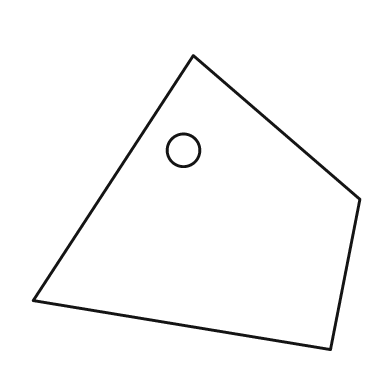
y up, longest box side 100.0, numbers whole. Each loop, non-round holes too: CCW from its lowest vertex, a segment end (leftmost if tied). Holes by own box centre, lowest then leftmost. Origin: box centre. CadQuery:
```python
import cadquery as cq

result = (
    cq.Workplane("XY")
    .moveTo(41.0, -45.0)
    .lineTo(50.0, 1.0)
    .lineTo(-1.0, 45.0)
    .lineTo(-50.0, -30.0)
    .close()
    .moveTo(-4.0, 16.0)
    .circle(5.0)
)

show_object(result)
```